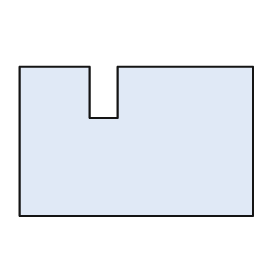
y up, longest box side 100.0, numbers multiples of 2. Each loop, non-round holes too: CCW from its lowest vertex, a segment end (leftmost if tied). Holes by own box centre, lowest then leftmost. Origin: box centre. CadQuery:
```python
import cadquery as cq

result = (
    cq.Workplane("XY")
    .moveTo(-50.0, -32.0)
    .lineTo(50.0, -32.0)
    .lineTo(50.0, 32.0)
    .lineTo(-8.0, 32.0)
    .lineTo(-8.0, 10.0)
    .lineTo(-20.0, 10.0)
    .lineTo(-20.0, 32.0)
    .lineTo(-50.0, 32.0)
    .close()
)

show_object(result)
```